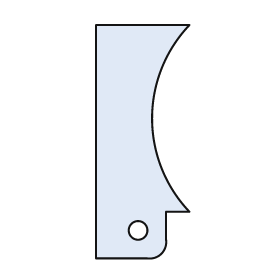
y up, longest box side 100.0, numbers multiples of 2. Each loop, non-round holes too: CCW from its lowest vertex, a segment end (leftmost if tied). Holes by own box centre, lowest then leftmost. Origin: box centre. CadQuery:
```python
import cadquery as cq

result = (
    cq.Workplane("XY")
    .moveTo(-20.0, -50.0)
    .lineTo(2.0, -50.0)
    .threePointArc((8.0, -48.0), (10.0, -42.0))
    .lineTo(10.0, -30.0)
    .lineTo(20.0, -30.0)
    .threePointArc((4.0, 10.0), (20.0, 50.0))
    .lineTo(-20.0, 50.0)
    .close()
    .moveTo(-2.0, -38.0)
    .circle(4.0)
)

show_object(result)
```